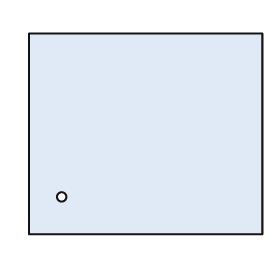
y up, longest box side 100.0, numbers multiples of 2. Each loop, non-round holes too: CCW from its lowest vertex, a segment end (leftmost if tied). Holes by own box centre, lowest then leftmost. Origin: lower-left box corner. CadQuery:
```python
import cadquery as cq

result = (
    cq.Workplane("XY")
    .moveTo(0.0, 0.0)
    .lineTo(100.0, 0.0)
    .lineTo(100.0, 86.0)
    .lineTo(0.0, 86.0)
    .close()
    .moveTo(14.0, 16.0)
    .circle(2.0)
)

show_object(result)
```